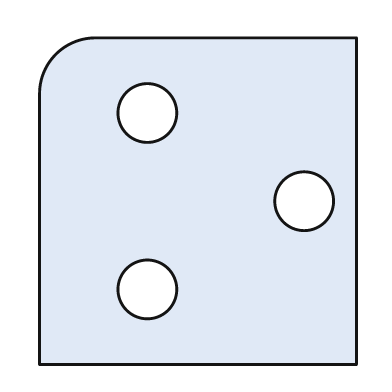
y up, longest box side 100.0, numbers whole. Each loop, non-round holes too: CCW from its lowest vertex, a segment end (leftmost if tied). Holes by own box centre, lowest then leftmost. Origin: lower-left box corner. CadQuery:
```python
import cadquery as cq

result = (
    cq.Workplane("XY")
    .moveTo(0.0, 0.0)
    .lineTo(97.0, 0.0)
    .lineTo(97.0, 100.0)
    .lineTo(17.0, 100.0)
    .threePointArc((5.0, 95.0), (0.0, 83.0))
    .close()
    .moveTo(33.0, 23.0)
    .circle(9.0)
    .moveTo(81.0, 50.0)
    .circle(9.0)
    .moveTo(33.0, 77.0)
    .circle(9.0)
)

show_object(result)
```